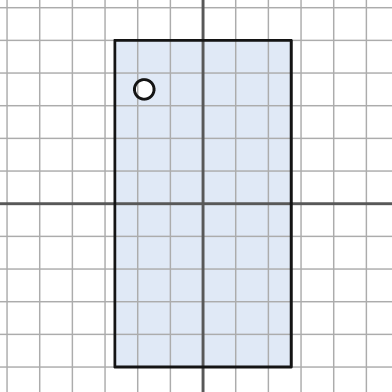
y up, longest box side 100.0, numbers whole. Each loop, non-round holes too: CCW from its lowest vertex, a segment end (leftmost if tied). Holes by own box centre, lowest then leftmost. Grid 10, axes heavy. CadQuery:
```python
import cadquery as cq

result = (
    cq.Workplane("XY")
    .moveTo(-27.0, -50.0)
    .lineTo(27.0, -50.0)
    .lineTo(27.0, 50.0)
    .lineTo(-27.0, 50.0)
    .close()
    .moveTo(-18.0, 35.0)
    .circle(3.0)
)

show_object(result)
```